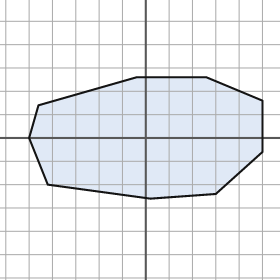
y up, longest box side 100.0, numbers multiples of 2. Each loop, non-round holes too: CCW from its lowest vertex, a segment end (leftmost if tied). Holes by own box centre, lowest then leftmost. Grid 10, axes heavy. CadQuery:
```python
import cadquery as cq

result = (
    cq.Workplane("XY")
    .moveTo(2.0, -26.0)
    .lineTo(30.0, -24.0)
    .lineTo(50.0, -6.0)
    .lineTo(50.0, 16.0)
    .lineTo(26.0, 26.0)
    .lineTo(-4.0, 26.0)
    .lineTo(-46.0, 14.0)
    .lineTo(-50.0, 0.0)
    .lineTo(-42.0, -20.0)
    .close()
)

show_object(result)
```